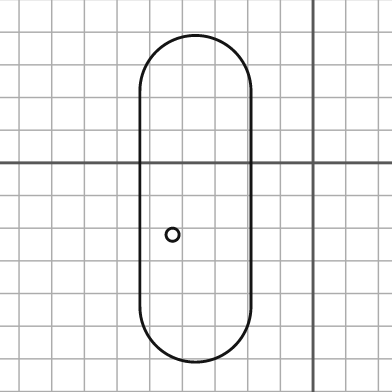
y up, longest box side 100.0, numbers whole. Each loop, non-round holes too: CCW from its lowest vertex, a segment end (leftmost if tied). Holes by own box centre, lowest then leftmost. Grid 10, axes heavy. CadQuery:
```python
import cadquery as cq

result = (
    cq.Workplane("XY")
    .moveTo(-53.0, -44.0)
    .threePointArc((-36.0, -61.0), (-19.0, -44.0))
    .lineTo(-19.0, 22.0)
    .threePointArc((-36.0, 39.0), (-53.0, 22.0))
    .close()
    .moveTo(-43.0, -22.0)
    .circle(2.0)
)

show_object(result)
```